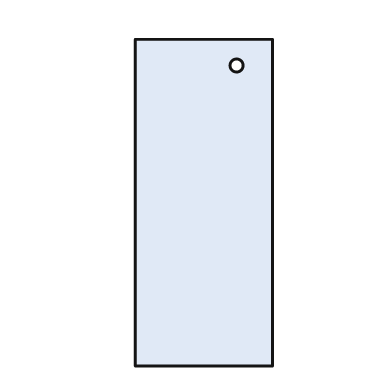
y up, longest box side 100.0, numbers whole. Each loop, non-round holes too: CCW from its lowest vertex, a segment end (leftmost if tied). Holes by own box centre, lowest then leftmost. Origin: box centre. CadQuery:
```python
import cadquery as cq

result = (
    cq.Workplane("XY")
    .moveTo(-21.0, -50.0)
    .lineTo(21.0, -50.0)
    .lineTo(21.0, 50.0)
    .lineTo(-21.0, 50.0)
    .close()
    .moveTo(10.0, 42.0)
    .circle(2.0)
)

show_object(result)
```